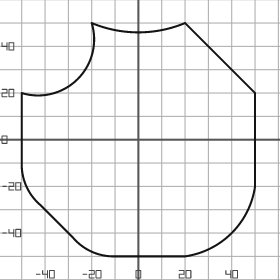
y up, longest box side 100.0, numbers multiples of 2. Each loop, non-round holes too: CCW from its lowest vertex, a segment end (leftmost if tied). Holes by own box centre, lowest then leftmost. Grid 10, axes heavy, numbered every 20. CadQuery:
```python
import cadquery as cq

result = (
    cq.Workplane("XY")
    .moveTo(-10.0, -50.0)
    .lineTo(20.0, -50.0)
    .threePointArc((40.0, -40.0), (50.0, -20.0))
    .lineTo(50.0, 20.0)
    .lineTo(20.0, 50.0)
    .threePointArc((0.0, 46.0), (-20.0, 50.0))
    .threePointArc((-26.0, 26.0), (-50.0, 20.0))
    .lineTo(-50.0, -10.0)
    .threePointArc((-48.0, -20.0), (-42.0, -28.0))
    .lineTo(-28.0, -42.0)
    .threePointArc((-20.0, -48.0), (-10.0, -50.0))
    .close()
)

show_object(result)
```